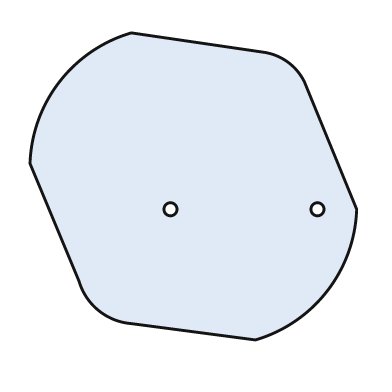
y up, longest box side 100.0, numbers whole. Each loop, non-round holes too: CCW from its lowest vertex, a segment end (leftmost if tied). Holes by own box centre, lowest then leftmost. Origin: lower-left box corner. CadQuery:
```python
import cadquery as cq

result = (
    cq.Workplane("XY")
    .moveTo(69.0, 0.0)
    .threePointArc((91.0, 15.0), (100.0, 40.0))
    .lineTo(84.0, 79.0)
    .threePointArc((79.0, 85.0), (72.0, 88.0))
    .lineTo(31.0, 94.0)
    .threePointArc((9.0, 79.0), (0.0, 54.0))
    .lineTo(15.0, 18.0)
    .threePointArc((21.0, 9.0), (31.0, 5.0))
    .close()
    .moveTo(43.0, 40.0)
    .circle(2.0)
    .moveTo(88.0, 40.0)
    .circle(2.0)
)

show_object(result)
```